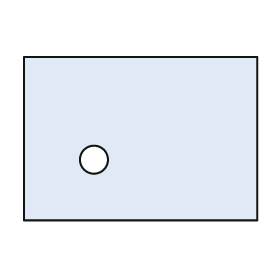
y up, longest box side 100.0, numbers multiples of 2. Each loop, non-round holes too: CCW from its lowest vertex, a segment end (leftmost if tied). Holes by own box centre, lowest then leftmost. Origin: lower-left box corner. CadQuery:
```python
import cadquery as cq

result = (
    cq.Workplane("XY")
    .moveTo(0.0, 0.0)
    .lineTo(100.0, 0.0)
    .lineTo(100.0, 70.0)
    .lineTo(0.0, 70.0)
    .close()
    .moveTo(30.0, 26.0)
    .circle(6.0)
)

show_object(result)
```